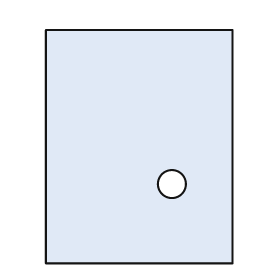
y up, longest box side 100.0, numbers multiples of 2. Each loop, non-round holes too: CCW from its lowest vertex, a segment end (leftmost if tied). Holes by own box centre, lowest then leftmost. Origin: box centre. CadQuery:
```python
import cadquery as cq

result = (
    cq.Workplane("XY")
    .moveTo(-40.0, -50.0)
    .lineTo(40.0, -50.0)
    .lineTo(40.0, 50.0)
    .lineTo(-40.0, 50.0)
    .close()
    .moveTo(14.0, -16.0)
    .circle(6.0)
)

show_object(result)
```